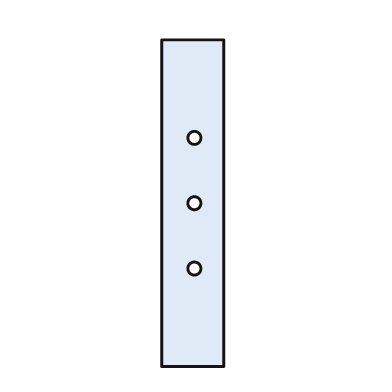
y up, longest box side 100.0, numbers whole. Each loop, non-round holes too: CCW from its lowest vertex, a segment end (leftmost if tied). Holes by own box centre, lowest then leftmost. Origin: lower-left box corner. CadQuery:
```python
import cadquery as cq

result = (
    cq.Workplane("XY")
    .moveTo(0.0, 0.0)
    .lineTo(19.0, 0.0)
    .lineTo(19.0, 100.0)
    .lineTo(0.0, 100.0)
    .close()
    .moveTo(10.0, 30.0)
    .circle(2.0)
    .moveTo(10.0, 50.0)
    .circle(2.0)
    .moveTo(10.0, 70.0)
    .circle(2.0)
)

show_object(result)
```